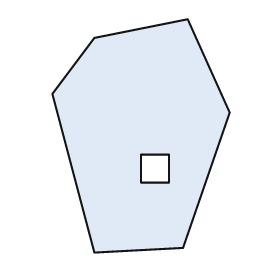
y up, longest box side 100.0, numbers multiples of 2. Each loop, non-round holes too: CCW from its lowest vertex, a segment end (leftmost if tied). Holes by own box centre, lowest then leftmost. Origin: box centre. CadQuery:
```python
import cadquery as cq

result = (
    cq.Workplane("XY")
    .moveTo(-20.0, -50.0)
    .lineTo(18.0, -48.0)
    .lineTo(38.0, 10.0)
    .lineTo(20.0, 50.0)
    .lineTo(-20.0, 42.0)
    .lineTo(-38.0, 18.0)
    .close()
    .moveTo(0.0, -20.0)
    .lineTo(12.0, -20.0)
    .lineTo(12.0, -8.0)
    .lineTo(0.0, -8.0)
    .close()
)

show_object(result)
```